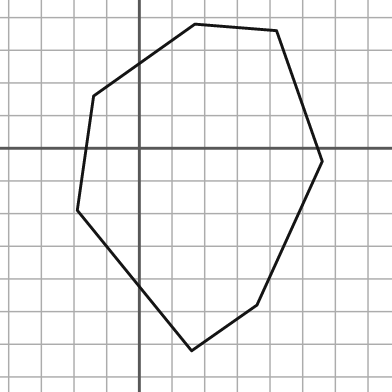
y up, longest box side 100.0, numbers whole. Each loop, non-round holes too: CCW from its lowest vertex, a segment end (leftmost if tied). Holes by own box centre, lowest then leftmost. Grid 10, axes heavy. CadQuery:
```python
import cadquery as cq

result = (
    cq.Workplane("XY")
    .moveTo(16.0, -62.0)
    .lineTo(36.0, -48.0)
    .lineTo(56.0, -4.0)
    .lineTo(42.0, 36.0)
    .lineTo(17.0, 38.0)
    .lineTo(-14.0, 16.0)
    .lineTo(-19.0, -19.0)
    .close()
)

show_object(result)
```